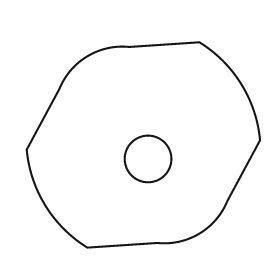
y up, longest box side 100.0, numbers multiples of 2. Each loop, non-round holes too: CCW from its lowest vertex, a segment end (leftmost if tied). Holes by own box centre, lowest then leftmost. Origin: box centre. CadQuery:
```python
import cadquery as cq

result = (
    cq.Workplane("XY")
    .moveTo(-24.0, -44.0)
    .lineTo(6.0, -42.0)
    .threePointArc((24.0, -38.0), (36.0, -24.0))
    .lineTo(50.0, 2.0)
    .threePointArc((42.0, 26.0), (24.0, 44.0))
    .lineTo(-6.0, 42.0)
    .threePointArc((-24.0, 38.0), (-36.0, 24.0))
    .lineTo(-50.0, -2.0)
    .threePointArc((-42.0, -26.0), (-24.0, -44.0))
    .close()
    .moveTo(2.0, -6.0)
    .circle(10.0)
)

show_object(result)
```